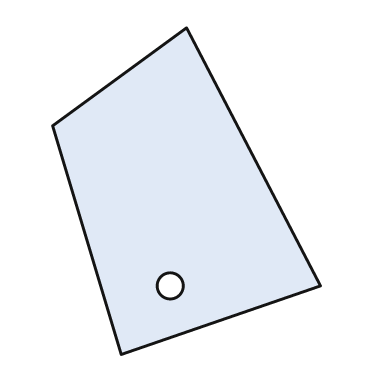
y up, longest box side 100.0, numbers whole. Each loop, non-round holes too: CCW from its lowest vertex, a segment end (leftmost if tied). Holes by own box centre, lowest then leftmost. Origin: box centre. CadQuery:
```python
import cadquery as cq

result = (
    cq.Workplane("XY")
    .moveTo(-20.0, -50.0)
    .lineTo(41.0, -29.0)
    .lineTo(0.0, 50.0)
    .lineTo(-41.0, 20.0)
    .close()
    .moveTo(-5.0, -29.0)
    .circle(4.0)
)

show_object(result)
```